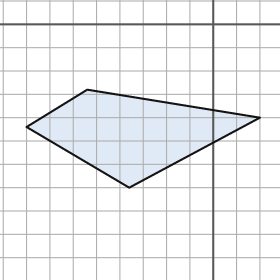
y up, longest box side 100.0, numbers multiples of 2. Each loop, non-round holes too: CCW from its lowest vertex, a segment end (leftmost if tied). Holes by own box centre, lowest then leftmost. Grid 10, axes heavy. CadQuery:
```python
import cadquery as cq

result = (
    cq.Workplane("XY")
    .moveTo(-36.0, -70.0)
    .lineTo(20.0, -40.0)
    .lineTo(-54.0, -28.0)
    .lineTo(-80.0, -44.0)
    .close()
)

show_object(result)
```